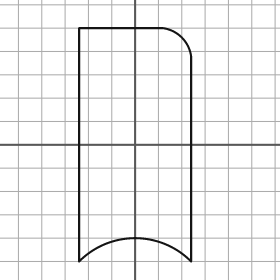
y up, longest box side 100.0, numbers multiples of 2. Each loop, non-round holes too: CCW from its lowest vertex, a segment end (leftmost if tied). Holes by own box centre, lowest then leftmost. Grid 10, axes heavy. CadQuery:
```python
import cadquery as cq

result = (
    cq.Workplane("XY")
    .moveTo(-24.0, -50.0)
    .threePointArc((0.0, -40.0), (24.0, -50.0))
    .lineTo(24.0, 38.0)
    .threePointArc((20.0, 46.0), (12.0, 50.0))
    .lineTo(-24.0, 50.0)
    .close()
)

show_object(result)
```